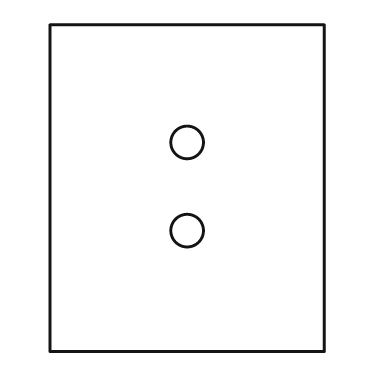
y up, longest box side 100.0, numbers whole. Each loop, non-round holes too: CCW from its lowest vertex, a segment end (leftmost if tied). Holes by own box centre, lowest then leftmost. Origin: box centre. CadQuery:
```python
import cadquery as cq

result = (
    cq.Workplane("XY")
    .moveTo(-42.0, -50.0)
    .lineTo(42.0, -50.0)
    .lineTo(42.0, 50.0)
    .lineTo(-42.0, 50.0)
    .close()
    .moveTo(0.0, -13.0)
    .circle(5.0)
    .moveTo(0.0, 14.0)
    .circle(5.0)
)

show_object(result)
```